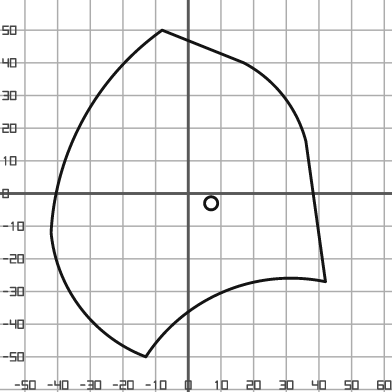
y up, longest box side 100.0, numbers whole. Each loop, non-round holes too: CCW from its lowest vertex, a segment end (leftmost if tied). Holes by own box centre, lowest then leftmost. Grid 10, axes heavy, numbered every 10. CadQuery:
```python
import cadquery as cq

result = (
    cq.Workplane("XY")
    .moveTo(-13.0, -50.0)
    .threePointArc((11.0, -30.0), (42.0, -27.0))
    .lineTo(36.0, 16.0)
    .threePointArc((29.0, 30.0), (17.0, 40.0))
    .lineTo(-8.0, 50.0)
    .threePointArc((-32.0, 23.0), (-42.0, -12.0))
    .threePointArc((-33.0, -35.0), (-13.0, -50.0))
    .close()
    .moveTo(7.0, -3.0)
    .circle(2.0)
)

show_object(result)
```